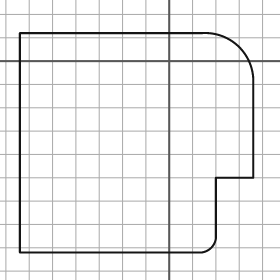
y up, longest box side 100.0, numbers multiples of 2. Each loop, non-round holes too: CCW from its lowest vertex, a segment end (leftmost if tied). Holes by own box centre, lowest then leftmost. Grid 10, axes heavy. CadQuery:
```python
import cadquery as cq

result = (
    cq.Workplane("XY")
    .moveTo(-64.0, -82.0)
    .lineTo(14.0, -82.0)
    .threePointArc((18.0, -80.0), (20.0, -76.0))
    .lineTo(20.0, -50.0)
    .lineTo(36.0, -50.0)
    .lineTo(36.0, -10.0)
    .threePointArc((30.0, 6.0), (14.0, 12.0))
    .lineTo(-64.0, 12.0)
    .close()
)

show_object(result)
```